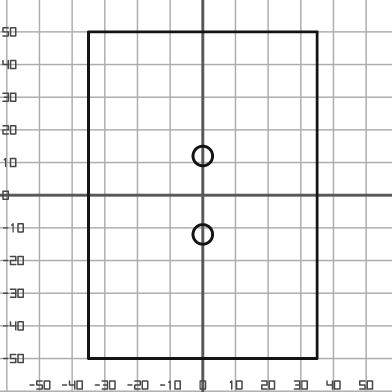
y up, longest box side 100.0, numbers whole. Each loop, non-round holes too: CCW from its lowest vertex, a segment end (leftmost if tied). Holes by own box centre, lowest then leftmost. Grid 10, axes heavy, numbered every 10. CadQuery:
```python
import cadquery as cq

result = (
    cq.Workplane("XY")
    .moveTo(-35.0, -50.0)
    .lineTo(35.0, -50.0)
    .lineTo(35.0, 50.0)
    .lineTo(-35.0, 50.0)
    .close()
    .moveTo(0.0, -12.0)
    .circle(3.0)
    .moveTo(0.0, 12.0)
    .circle(3.0)
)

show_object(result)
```